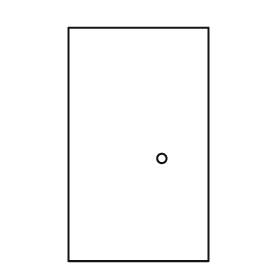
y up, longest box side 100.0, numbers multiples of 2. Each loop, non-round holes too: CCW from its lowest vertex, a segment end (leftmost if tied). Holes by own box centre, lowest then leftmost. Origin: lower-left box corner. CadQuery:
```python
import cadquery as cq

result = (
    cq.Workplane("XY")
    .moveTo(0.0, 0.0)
    .lineTo(60.0, 0.0)
    .lineTo(60.0, 100.0)
    .lineTo(0.0, 100.0)
    .close()
    .moveTo(40.0, 44.0)
    .circle(2.0)
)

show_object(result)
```